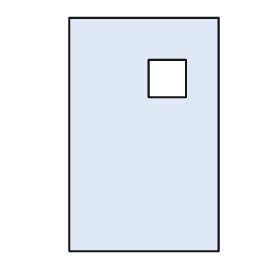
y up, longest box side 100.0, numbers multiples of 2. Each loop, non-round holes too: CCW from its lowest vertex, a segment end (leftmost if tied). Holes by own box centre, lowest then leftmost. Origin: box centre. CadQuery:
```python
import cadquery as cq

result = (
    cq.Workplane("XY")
    .moveTo(-32.0, -50.0)
    .lineTo(32.0, -50.0)
    .lineTo(32.0, 50.0)
    .lineTo(-32.0, 50.0)
    .close()
    .moveTo(2.0, 16.0)
    .lineTo(18.0, 16.0)
    .lineTo(18.0, 32.0)
    .lineTo(2.0, 32.0)
    .close()
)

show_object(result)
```